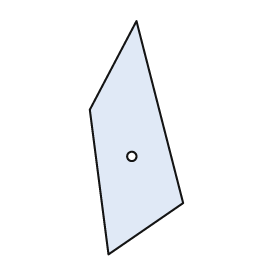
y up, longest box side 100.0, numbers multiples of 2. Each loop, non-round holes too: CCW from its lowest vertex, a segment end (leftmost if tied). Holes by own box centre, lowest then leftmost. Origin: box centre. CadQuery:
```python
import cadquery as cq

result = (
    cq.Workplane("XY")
    .moveTo(-12.0, -50.0)
    .lineTo(20.0, -28.0)
    .lineTo(0.0, 50.0)
    .lineTo(-20.0, 12.0)
    .close()
    .moveTo(-2.0, -8.0)
    .circle(2.0)
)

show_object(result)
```